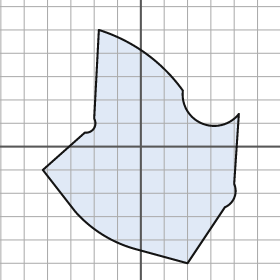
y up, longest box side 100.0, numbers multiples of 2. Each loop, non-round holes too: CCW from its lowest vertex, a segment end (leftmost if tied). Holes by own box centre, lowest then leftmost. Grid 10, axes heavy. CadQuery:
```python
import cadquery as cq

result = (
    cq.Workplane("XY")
    .moveTo(20.0, -50.0)
    .lineTo(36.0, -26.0)
    .threePointArc((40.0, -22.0), (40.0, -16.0))
    .lineTo(42.0, 14.0)
    .threePointArc((26.0, 10.0), (18.0, 24.0))
    .threePointArc((2.0, 40.0), (-18.0, 50.0))
    .lineTo(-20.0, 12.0)
    .threePointArc((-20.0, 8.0), (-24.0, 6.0))
    .lineTo(-42.0, -10.0)
    .lineTo(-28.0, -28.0)
    .threePointArc((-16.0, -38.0), (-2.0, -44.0))
    .close()
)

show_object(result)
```